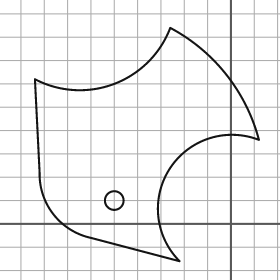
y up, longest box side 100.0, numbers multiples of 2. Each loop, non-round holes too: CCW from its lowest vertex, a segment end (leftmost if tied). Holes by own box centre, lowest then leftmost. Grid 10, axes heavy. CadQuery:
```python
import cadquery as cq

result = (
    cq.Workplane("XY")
    .moveTo(-22.0, -16.0)
    .threePointArc((-26.0, 24.0), (12.0, 36.0))
    .threePointArc((-2.0, 64.0), (-26.0, 84.0))
    .threePointArc((-50.0, 60.0), (-84.0, 62.0))
    .lineTo(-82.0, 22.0)
    .threePointArc((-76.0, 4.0), (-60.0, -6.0))
    .close()
    .moveTo(-50.0, 10.0)
    .circle(4.0)
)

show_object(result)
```